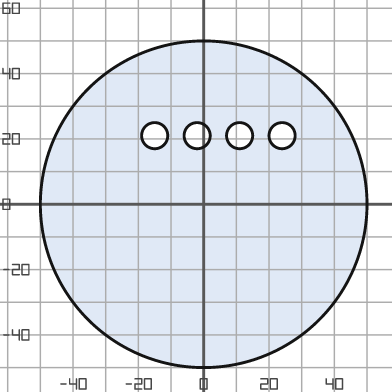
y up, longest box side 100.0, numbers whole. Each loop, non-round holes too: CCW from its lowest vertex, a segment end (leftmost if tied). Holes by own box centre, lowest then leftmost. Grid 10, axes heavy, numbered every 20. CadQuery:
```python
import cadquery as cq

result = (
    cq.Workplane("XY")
    .moveTo(0.0, 0.0)
    .circle(50.0)
    .moveTo(-15.0, 21.0)
    .circle(4.0)
    .moveTo(-2.0, 21.0)
    .circle(4.0)
    .moveTo(11.0, 21.0)
    .circle(4.0)
    .moveTo(24.0, 21.0)
    .circle(4.0)
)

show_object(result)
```